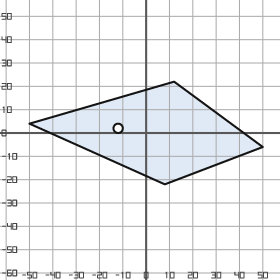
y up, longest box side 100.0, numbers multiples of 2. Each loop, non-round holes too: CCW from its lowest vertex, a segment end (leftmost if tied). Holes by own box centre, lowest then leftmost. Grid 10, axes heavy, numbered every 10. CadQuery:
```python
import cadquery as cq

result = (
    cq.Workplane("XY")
    .moveTo(8.0, -22.0)
    .lineTo(50.0, -6.0)
    .lineTo(12.0, 22.0)
    .lineTo(-50.0, 4.0)
    .close()
    .moveTo(-12.0, 2.0)
    .circle(2.0)
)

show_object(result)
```